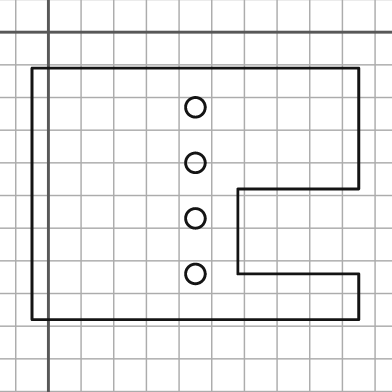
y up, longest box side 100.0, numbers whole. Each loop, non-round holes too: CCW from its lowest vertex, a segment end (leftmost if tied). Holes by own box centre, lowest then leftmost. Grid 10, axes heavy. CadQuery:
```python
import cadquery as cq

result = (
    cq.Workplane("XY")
    .moveTo(-5.0, -88.0)
    .lineTo(95.0, -88.0)
    .lineTo(95.0, -74.0)
    .lineTo(58.0, -74.0)
    .lineTo(58.0, -48.0)
    .lineTo(95.0, -48.0)
    .lineTo(95.0, -11.0)
    .lineTo(-5.0, -11.0)
    .close()
    .moveTo(45.0, -74.0)
    .circle(3.0)
    .moveTo(45.0, -57.0)
    .circle(3.0)
    .moveTo(45.0, -40.0)
    .circle(3.0)
    .moveTo(45.0, -23.0)
    .circle(3.0)
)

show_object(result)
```